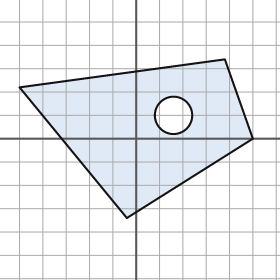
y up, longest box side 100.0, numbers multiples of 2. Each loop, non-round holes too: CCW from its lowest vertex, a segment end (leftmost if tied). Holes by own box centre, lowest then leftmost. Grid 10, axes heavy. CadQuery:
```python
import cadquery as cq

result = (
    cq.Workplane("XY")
    .moveTo(-4.0, -34.0)
    .lineTo(50.0, 0.0)
    .lineTo(38.0, 34.0)
    .lineTo(-50.0, 22.0)
    .close()
    .moveTo(16.0, 10.0)
    .circle(8.0)
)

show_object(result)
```